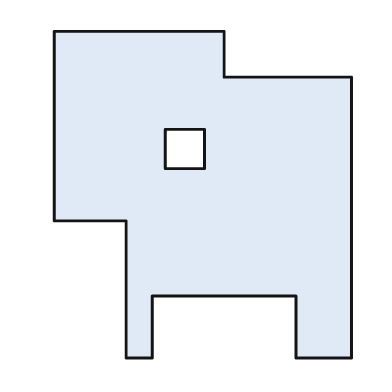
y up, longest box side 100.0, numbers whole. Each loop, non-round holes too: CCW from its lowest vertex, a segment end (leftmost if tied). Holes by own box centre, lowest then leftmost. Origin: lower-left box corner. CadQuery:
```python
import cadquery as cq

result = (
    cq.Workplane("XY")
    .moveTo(22.0, 0.0)
    .lineTo(30.0, 0.0)
    .lineTo(30.0, 19.0)
    .lineTo(74.0, 19.0)
    .lineTo(74.0, 0.0)
    .lineTo(91.0, 0.0)
    .lineTo(91.0, 86.0)
    .lineTo(52.0, 86.0)
    .lineTo(52.0, 100.0)
    .lineTo(0.0, 100.0)
    .lineTo(0.0, 42.0)
    .lineTo(22.0, 42.0)
    .close()
    .moveTo(34.0, 58.0)
    .lineTo(46.0, 58.0)
    .lineTo(46.0, 70.0)
    .lineTo(34.0, 70.0)
    .close()
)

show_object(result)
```